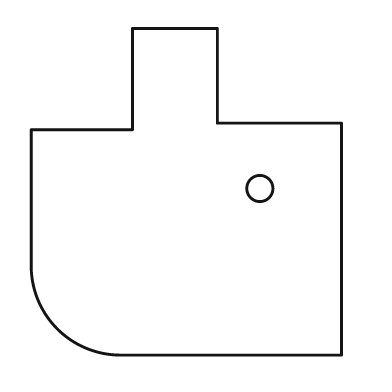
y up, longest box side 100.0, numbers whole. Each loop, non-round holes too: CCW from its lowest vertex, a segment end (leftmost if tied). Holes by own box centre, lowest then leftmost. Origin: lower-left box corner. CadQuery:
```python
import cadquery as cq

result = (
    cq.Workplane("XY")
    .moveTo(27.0, 0.0)
    .lineTo(95.0, 0.0)
    .lineTo(95.0, 71.0)
    .lineTo(57.0, 71.0)
    .lineTo(57.0, 100.0)
    .lineTo(31.0, 100.0)
    .lineTo(31.0, 69.0)
    .lineTo(0.0, 69.0)
    .lineTo(0.0, 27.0)
    .threePointArc((8.0, 8.0), (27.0, 0.0))
    .close()
    .moveTo(70.0, 51.0)
    .circle(4.0)
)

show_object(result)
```